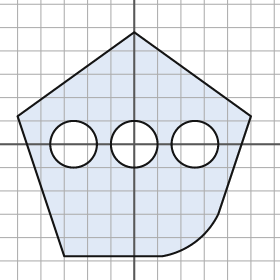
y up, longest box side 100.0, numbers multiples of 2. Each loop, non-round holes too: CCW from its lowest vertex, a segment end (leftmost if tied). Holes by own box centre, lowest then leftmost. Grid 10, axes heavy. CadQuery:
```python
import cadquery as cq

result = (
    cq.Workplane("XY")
    .moveTo(-30.0, -48.0)
    .lineTo(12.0, -48.0)
    .threePointArc((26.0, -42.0), (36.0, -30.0))
    .lineTo(50.0, 12.0)
    .lineTo(0.0, 48.0)
    .lineTo(-50.0, 12.0)
    .close()
    .moveTo(-26.0, 0.0)
    .circle(10.0)
    .moveTo(0.0, 0.0)
    .circle(10.0)
    .moveTo(26.0, 0.0)
    .circle(10.0)
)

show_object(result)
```